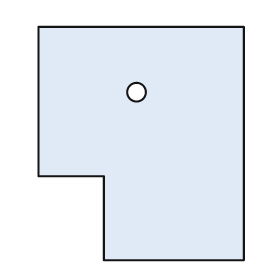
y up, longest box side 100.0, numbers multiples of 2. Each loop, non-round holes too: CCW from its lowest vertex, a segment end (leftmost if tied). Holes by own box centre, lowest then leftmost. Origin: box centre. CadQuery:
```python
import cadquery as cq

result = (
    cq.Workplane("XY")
    .moveTo(-16.0, -50.0)
    .lineTo(44.0, -50.0)
    .lineTo(44.0, 50.0)
    .lineTo(-44.0, 50.0)
    .lineTo(-44.0, -14.0)
    .lineTo(-16.0, -14.0)
    .close()
    .moveTo(-2.0, 22.0)
    .circle(4.0)
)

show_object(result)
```